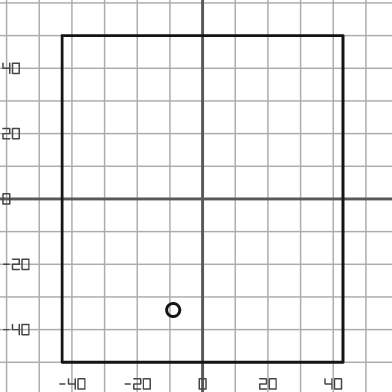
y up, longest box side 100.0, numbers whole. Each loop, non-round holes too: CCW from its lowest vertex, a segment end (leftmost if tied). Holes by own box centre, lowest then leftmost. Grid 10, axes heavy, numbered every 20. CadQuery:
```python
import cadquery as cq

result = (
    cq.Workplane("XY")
    .moveTo(-43.0, -50.0)
    .lineTo(43.0, -50.0)
    .lineTo(43.0, 50.0)
    .lineTo(-43.0, 50.0)
    .close()
    .moveTo(-9.0, -34.0)
    .circle(2.0)
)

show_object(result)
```